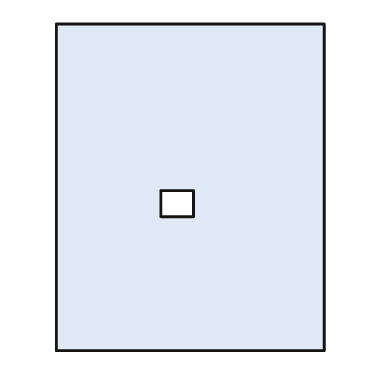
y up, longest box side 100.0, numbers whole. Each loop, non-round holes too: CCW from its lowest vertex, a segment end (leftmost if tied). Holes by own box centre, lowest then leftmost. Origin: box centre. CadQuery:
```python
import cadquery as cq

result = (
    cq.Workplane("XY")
    .moveTo(-41.0, -50.0)
    .lineTo(41.0, -50.0)
    .lineTo(41.0, 50.0)
    .lineTo(-41.0, 50.0)
    .close()
    .moveTo(-9.0, -9.0)
    .lineTo(1.0, -9.0)
    .lineTo(1.0, -1.0)
    .lineTo(-9.0, -1.0)
    .close()
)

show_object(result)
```